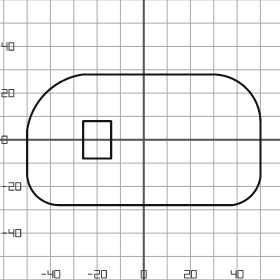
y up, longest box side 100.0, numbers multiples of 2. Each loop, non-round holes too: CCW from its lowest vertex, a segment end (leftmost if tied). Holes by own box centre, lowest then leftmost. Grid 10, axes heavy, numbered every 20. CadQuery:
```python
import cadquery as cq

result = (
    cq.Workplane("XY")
    .moveTo(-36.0, -28.0)
    .lineTo(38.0, -28.0)
    .threePointArc((46.0, -24.0), (50.0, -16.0))
    .lineTo(50.0, 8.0)
    .threePointArc((44.0, 22.0), (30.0, 28.0))
    .lineTo(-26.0, 28.0)
    .threePointArc((-42.0, 20.0), (-50.0, 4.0))
    .lineTo(-50.0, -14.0)
    .threePointArc((-46.0, -24.0), (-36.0, -28.0))
    .close()
    .moveTo(-26.0, -8.0)
    .lineTo(-14.0, -8.0)
    .lineTo(-14.0, 8.0)
    .lineTo(-26.0, 8.0)
    .close()
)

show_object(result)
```